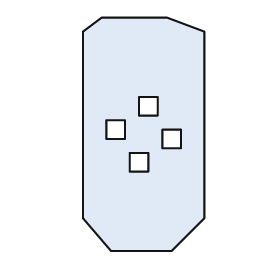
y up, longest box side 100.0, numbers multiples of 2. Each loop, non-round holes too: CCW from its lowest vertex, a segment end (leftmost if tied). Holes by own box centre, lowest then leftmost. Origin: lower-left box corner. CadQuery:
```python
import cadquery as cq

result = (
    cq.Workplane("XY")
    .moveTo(12.0, 0.0)
    .lineTo(38.0, 0.0)
    .lineTo(52.0, 14.0)
    .lineTo(52.0, 94.0)
    .lineTo(36.0, 100.0)
    .lineTo(8.0, 100.0)
    .lineTo(0.0, 94.0)
    .lineTo(0.0, 14.0)
    .close()
    .moveTo(20.0, 34.0)
    .lineTo(28.0, 34.0)
    .lineTo(28.0, 42.0)
    .lineTo(20.0, 42.0)
    .close()
    .moveTo(34.0, 44.0)
    .lineTo(42.0, 44.0)
    .lineTo(42.0, 52.0)
    .lineTo(34.0, 52.0)
    .close()
    .moveTo(10.0, 48.0)
    .lineTo(18.0, 48.0)
    .lineTo(18.0, 56.0)
    .lineTo(10.0, 56.0)
    .close()
    .moveTo(24.0, 58.0)
    .lineTo(32.0, 58.0)
    .lineTo(32.0, 66.0)
    .lineTo(24.0, 66.0)
    .close()
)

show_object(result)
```